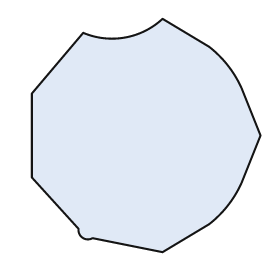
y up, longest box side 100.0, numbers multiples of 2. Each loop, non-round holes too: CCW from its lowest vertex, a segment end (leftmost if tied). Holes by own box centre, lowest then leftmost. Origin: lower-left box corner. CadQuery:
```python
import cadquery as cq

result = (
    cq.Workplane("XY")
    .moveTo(56.0, 0.0)
    .lineTo(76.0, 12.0)
    .threePointArc((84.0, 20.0), (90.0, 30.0))
    .lineTo(98.0, 50.0)
    .lineTo(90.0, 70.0)
    .threePointArc((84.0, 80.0), (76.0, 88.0))
    .lineTo(56.0, 100.0)
    .threePointArc((40.0, 92.0), (22.0, 94.0))
    .lineTo(0.0, 68.0)
    .lineTo(0.0, 32.0)
    .lineTo(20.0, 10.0)
    .threePointArc((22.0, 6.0), (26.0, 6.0))
    .close()
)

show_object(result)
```